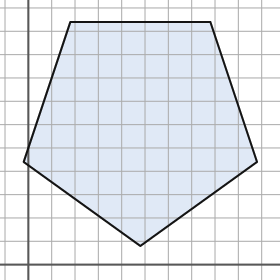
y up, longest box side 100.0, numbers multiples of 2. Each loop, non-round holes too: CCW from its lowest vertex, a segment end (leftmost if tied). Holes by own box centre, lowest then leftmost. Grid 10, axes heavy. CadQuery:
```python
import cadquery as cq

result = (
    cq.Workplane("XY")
    .moveTo(48.0, 8.0)
    .lineTo(98.0, 44.0)
    .lineTo(78.0, 104.0)
    .lineTo(18.0, 104.0)
    .lineTo(-2.0, 44.0)
    .close()
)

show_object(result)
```